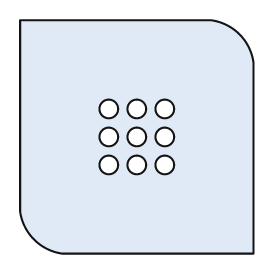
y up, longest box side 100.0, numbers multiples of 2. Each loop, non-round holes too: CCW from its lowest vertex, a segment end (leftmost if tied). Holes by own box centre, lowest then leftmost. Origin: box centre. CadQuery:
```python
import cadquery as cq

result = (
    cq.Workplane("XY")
    .moveTo(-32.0, -50.0)
    .lineTo(50.0, -50.0)
    .lineTo(50.0, 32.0)
    .threePointArc((44.0, 44.0), (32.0, 50.0))
    .lineTo(-50.0, 50.0)
    .lineTo(-50.0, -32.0)
    .threePointArc((-44.0, -44.0), (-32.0, -50.0))
    .close()
    .moveTo(-12.0, -12.0)
    .circle(4.0)
    .moveTo(0.0, -12.0)
    .circle(4.0)
    .moveTo(12.0, -12.0)
    .circle(4.0)
    .moveTo(-12.0, 0.0)
    .circle(4.0)
    .moveTo(0.0, 0.0)
    .circle(4.0)
    .moveTo(12.0, 0.0)
    .circle(4.0)
    .moveTo(-12.0, 12.0)
    .circle(4.0)
    .moveTo(0.0, 12.0)
    .circle(4.0)
    .moveTo(12.0, 12.0)
    .circle(4.0)
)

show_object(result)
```